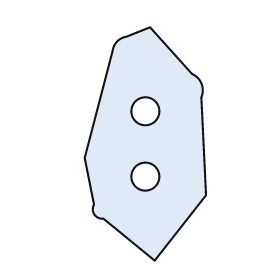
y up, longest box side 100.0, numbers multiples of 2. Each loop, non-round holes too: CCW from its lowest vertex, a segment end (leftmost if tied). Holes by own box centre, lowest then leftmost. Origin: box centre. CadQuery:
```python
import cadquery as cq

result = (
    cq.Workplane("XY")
    .moveTo(4.0, -50.0)
    .lineTo(26.0, -22.0)
    .lineTo(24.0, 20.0)
    .threePointArc((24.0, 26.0), (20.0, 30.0))
    .lineTo(2.0, 50.0)
    .lineTo(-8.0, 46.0)
    .threePointArc((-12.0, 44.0), (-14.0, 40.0))
    .lineTo(-26.0, -6.0)
    .lineTo(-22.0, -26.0)
    .threePointArc((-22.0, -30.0), (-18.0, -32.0))
    .close()
    .moveTo(0.0, -14.0)
    .circle(6.0)
    .moveTo(0.0, 14.0)
    .circle(6.0)
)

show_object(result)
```